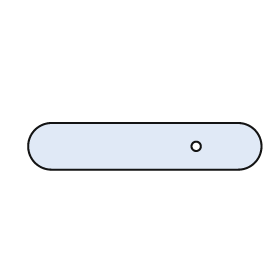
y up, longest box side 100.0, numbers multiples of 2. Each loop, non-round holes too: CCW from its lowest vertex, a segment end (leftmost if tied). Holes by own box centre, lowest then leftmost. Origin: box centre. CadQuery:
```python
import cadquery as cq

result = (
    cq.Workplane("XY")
    .moveTo(-40.0, -10.0)
    .lineTo(40.0, -10.0)
    .threePointArc((50.0, 0.0), (40.0, 10.0))
    .lineTo(-40.0, 10.0)
    .threePointArc((-50.0, 0.0), (-40.0, -10.0))
    .close()
    .moveTo(22.0, 0.0)
    .circle(2.0)
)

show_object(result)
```